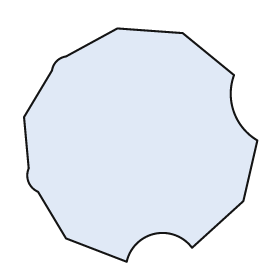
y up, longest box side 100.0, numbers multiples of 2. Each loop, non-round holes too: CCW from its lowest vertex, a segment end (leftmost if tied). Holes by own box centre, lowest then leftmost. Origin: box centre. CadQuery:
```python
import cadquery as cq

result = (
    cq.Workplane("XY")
    .moveTo(-6.0, -50.0)
    .threePointArc((6.0, -38.0), (22.0, -44.0))
    .lineTo(44.0, -24.0)
    .lineTo(50.0, 2.0)
    .threePointArc((40.0, 14.0), (40.0, 30.0))
    .lineTo(18.0, 48.0)
    .lineTo(-10.0, 50.0)
    .lineTo(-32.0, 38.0)
    .threePointArc((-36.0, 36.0), (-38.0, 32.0))
    .lineTo(-50.0, 12.0)
    .lineTo(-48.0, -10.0)
    .threePointArc((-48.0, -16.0), (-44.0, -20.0))
    .lineTo(-32.0, -40.0)
    .close()
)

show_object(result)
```